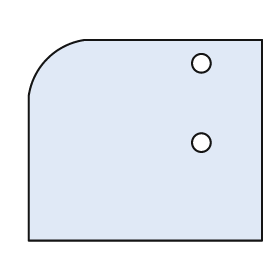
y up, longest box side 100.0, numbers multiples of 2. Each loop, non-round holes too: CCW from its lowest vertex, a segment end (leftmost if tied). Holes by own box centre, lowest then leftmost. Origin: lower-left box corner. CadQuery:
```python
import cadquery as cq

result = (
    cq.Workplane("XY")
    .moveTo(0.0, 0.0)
    .lineTo(100.0, 0.0)
    .lineTo(100.0, 86.0)
    .lineTo(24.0, 86.0)
    .threePointArc((8.0, 78.0), (0.0, 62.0))
    .close()
    .moveTo(74.0, 42.0)
    .circle(4.0)
    .moveTo(74.0, 76.0)
    .circle(4.0)
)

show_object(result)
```